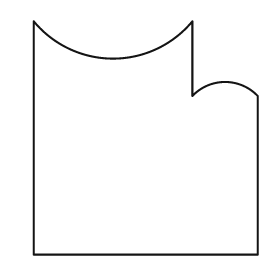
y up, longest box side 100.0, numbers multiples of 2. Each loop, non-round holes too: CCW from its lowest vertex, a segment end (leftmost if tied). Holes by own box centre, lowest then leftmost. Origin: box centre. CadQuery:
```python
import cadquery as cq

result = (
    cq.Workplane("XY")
    .moveTo(-48.0, -50.0)
    .lineTo(48.0, -50.0)
    .lineTo(48.0, 18.0)
    .threePointArc((34.0, 24.0), (20.0, 18.0))
    .lineTo(20.0, 50.0)
    .threePointArc((-14.0, 34.0), (-48.0, 50.0))
    .close()
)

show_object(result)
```